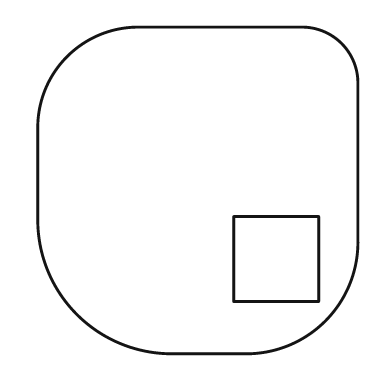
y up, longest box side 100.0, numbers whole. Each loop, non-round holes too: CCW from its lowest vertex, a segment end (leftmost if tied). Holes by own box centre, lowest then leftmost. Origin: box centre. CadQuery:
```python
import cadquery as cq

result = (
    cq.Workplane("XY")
    .moveTo(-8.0, -50.0)
    .lineTo(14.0, -50.0)
    .threePointArc((39.0, -40.0), (49.0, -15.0))
    .lineTo(49.0, 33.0)
    .threePointArc((44.0, 45.0), (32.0, 50.0))
    .lineTo(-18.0, 50.0)
    .threePointArc((-40.0, 41.0), (-49.0, 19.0))
    .lineTo(-49.0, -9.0)
    .threePointArc((-37.0, -38.0), (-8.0, -50.0))
    .close()
    .moveTo(11.0, -34.0)
    .lineTo(37.0, -34.0)
    .lineTo(37.0, -8.0)
    .lineTo(11.0, -8.0)
    .close()
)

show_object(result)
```